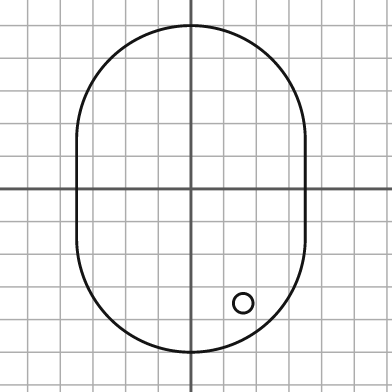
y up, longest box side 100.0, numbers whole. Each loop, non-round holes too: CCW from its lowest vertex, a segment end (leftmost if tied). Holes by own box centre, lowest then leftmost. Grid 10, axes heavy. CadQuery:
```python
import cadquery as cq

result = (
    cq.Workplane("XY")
    .moveTo(-35.0, -15.0)
    .threePointArc((0.0, -50.0), (35.0, -15.0))
    .lineTo(35.0, 15.0)
    .threePointArc((0.0, 50.0), (-35.0, 15.0))
    .close()
    .moveTo(16.0, -35.0)
    .circle(3.0)
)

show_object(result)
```